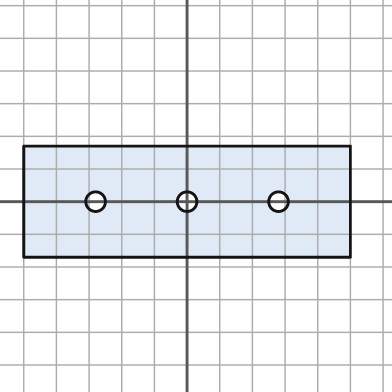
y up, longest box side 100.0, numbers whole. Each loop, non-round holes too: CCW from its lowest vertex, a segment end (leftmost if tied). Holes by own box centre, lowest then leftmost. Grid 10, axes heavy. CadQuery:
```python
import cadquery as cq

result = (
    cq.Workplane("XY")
    .moveTo(-50.0, -17.0)
    .lineTo(50.0, -17.0)
    .lineTo(50.0, 17.0)
    .lineTo(-50.0, 17.0)
    .close()
    .moveTo(-28.0, 0.0)
    .circle(3.0)
    .moveTo(0.0, 0.0)
    .circle(3.0)
    .moveTo(28.0, 0.0)
    .circle(3.0)
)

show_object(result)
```